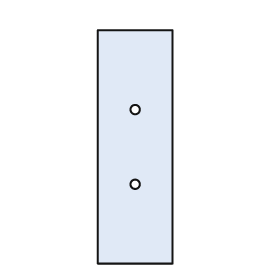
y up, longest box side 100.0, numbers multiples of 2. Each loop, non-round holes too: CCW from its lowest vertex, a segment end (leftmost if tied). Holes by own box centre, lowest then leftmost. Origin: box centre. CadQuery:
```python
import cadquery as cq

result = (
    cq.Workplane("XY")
    .moveTo(-16.0, -50.0)
    .lineTo(16.0, -50.0)
    .lineTo(16.0, 50.0)
    .lineTo(-16.0, 50.0)
    .close()
    .moveTo(0.0, -16.0)
    .circle(2.0)
    .moveTo(0.0, 16.0)
    .circle(2.0)
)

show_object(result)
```